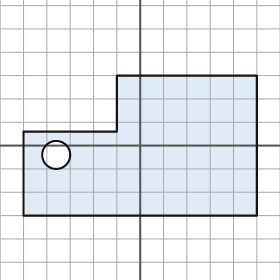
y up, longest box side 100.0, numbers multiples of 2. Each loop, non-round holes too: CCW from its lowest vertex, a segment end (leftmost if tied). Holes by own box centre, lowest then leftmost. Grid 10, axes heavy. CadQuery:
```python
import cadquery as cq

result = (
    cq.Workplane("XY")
    .moveTo(-50.0, -30.0)
    .lineTo(50.0, -30.0)
    .lineTo(50.0, 30.0)
    .lineTo(-10.0, 30.0)
    .lineTo(-10.0, 6.0)
    .lineTo(-50.0, 6.0)
    .close()
    .moveTo(-36.0, -4.0)
    .circle(6.0)
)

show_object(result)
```